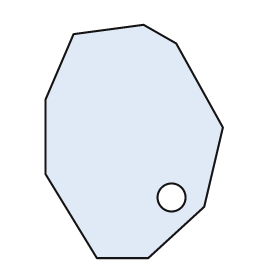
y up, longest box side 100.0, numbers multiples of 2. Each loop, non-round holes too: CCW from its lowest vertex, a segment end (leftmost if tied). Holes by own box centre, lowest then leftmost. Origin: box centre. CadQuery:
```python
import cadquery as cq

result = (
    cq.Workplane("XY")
    .moveTo(-16.0, -50.0)
    .lineTo(6.0, -50.0)
    .lineTo(30.0, -28.0)
    .lineTo(38.0, 6.0)
    .lineTo(18.0, 42.0)
    .lineTo(4.0, 50.0)
    .lineTo(-26.0, 46.0)
    .lineTo(-38.0, 18.0)
    .lineTo(-38.0, -14.0)
    .close()
    .moveTo(16.0, -24.0)
    .circle(6.0)
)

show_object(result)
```